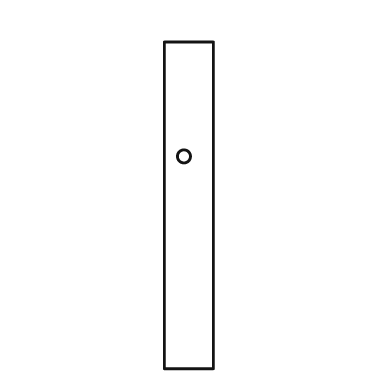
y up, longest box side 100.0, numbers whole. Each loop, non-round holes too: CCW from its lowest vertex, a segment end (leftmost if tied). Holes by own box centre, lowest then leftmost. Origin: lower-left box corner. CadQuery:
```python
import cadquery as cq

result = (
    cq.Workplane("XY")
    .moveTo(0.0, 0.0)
    .lineTo(15.0, 0.0)
    .lineTo(15.0, 100.0)
    .lineTo(0.0, 100.0)
    .close()
    .moveTo(6.0, 65.0)
    .circle(2.0)
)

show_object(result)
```